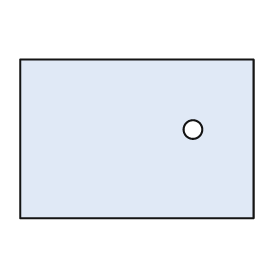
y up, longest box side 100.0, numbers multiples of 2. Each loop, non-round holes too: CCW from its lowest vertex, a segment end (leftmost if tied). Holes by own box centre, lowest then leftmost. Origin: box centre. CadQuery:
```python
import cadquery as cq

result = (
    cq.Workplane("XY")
    .moveTo(-50.0, -34.0)
    .lineTo(50.0, -34.0)
    .lineTo(50.0, 34.0)
    .lineTo(-50.0, 34.0)
    .close()
    .moveTo(24.0, 4.0)
    .circle(4.0)
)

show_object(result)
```